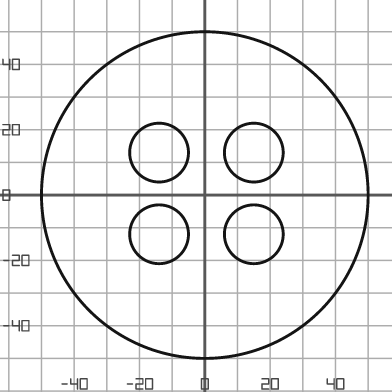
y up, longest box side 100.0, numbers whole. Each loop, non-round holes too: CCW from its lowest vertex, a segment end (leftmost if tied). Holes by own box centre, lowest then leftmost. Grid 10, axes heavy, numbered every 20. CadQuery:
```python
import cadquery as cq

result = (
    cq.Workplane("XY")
    .moveTo(0.0, 0.0)
    .circle(50.0)
    .moveTo(-14.0, -12.0)
    .circle(9.0)
    .moveTo(15.0, -12.0)
    .circle(9.0)
    .moveTo(-14.0, 13.0)
    .circle(9.0)
    .moveTo(15.0, 13.0)
    .circle(9.0)
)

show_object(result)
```